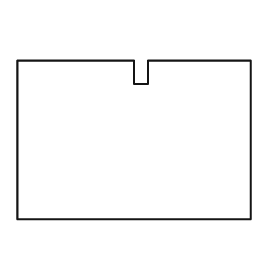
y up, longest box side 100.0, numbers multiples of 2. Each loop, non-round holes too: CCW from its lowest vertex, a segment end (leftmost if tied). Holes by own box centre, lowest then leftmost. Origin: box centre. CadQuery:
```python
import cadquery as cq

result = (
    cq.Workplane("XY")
    .moveTo(-50.0, -34.0)
    .lineTo(50.0, -34.0)
    .lineTo(50.0, 34.0)
    .lineTo(6.0, 34.0)
    .lineTo(6.0, 24.0)
    .lineTo(0.0, 24.0)
    .lineTo(0.0, 34.0)
    .lineTo(-50.0, 34.0)
    .close()
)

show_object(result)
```